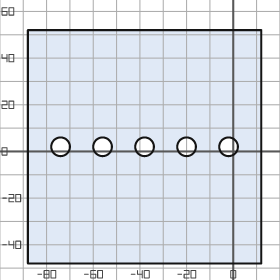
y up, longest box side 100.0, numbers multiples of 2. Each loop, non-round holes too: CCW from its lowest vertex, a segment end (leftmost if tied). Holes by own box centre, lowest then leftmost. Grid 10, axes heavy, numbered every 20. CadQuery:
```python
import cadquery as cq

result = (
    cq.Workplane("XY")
    .moveTo(-88.0, -48.0)
    .lineTo(12.0, -48.0)
    .lineTo(12.0, 52.0)
    .lineTo(-88.0, 52.0)
    .close()
    .moveTo(-74.0, 2.0)
    .circle(4.0)
    .moveTo(-56.0, 2.0)
    .circle(4.0)
    .moveTo(-38.0, 2.0)
    .circle(4.0)
    .moveTo(-20.0, 2.0)
    .circle(4.0)
    .moveTo(-2.0, 2.0)
    .circle(4.0)
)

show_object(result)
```